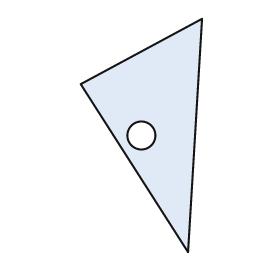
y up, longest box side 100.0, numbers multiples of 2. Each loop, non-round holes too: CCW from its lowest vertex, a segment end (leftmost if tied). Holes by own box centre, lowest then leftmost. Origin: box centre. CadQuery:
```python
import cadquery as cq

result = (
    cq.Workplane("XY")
    .moveTo(20.0, -50.0)
    .lineTo(26.0, 50.0)
    .lineTo(-26.0, 22.0)
    .close()
    .moveTo(0.0, 0.0)
    .circle(6.0)
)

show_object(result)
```